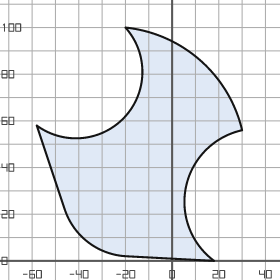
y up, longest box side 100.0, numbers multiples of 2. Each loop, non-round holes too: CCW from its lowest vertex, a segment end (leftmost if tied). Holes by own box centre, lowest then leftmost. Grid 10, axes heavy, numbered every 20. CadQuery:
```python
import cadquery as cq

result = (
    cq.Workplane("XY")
    .moveTo(18.0, 0.0)
    .threePointArc((6.0, 32.0), (30.0, 56.0))
    .threePointArc((12.0, 86.0), (-20.0, 100.0))
    .threePointArc((-20.0, 62.0), (-58.0, 58.0))
    .lineTo(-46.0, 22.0)
    .threePointArc((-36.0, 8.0), (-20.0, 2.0))
    .close()
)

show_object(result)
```